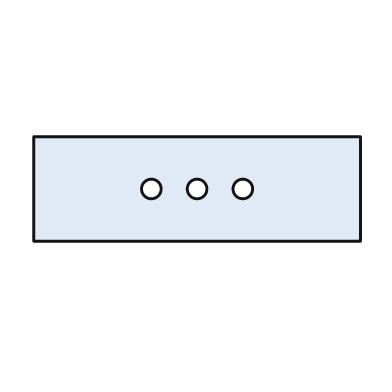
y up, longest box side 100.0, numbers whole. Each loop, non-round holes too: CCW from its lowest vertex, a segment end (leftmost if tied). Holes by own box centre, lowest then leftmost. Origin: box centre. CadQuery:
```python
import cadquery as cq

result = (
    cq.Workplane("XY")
    .moveTo(-50.0, -16.0)
    .lineTo(50.0, -16.0)
    .lineTo(50.0, 16.0)
    .lineTo(-50.0, 16.0)
    .close()
    .moveTo(-14.0, 0.0)
    .circle(3.0)
    .moveTo(0.0, 0.0)
    .circle(3.0)
    .moveTo(14.0, 0.0)
    .circle(3.0)
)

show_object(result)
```